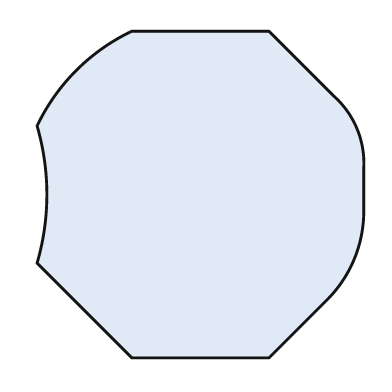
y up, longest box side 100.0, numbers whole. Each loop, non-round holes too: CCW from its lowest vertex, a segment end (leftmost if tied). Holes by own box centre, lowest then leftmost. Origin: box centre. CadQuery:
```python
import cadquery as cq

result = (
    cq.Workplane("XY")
    .moveTo(-21.0, -50.0)
    .lineTo(21.0, -50.0)
    .lineTo(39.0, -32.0)
    .threePointArc((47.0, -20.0), (50.0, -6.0))
    .lineTo(50.0, 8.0)
    .threePointArc((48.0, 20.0), (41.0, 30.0))
    .lineTo(21.0, 50.0)
    .lineTo(-21.0, 50.0)
    .threePointArc((-38.0, 38.0), (-50.0, 21.0))
    .threePointArc((-47.0, 0.0), (-50.0, -21.0))
    .close()
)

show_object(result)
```